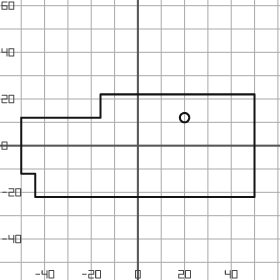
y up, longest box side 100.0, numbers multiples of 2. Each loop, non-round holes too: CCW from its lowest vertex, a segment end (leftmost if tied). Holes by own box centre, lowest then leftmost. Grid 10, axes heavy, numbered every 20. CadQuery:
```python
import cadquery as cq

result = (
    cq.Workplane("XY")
    .moveTo(-44.0, -22.0)
    .lineTo(50.0, -22.0)
    .lineTo(50.0, 22.0)
    .lineTo(-16.0, 22.0)
    .lineTo(-16.0, 12.0)
    .lineTo(-50.0, 12.0)
    .lineTo(-50.0, -12.0)
    .lineTo(-44.0, -12.0)
    .close()
    .moveTo(20.0, 12.0)
    .circle(2.0)
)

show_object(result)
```